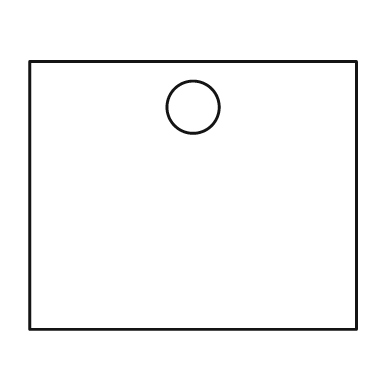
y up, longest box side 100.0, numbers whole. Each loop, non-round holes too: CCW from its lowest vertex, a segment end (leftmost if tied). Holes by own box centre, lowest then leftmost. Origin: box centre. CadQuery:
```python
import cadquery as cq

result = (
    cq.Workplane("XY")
    .moveTo(-50.0, -41.0)
    .lineTo(50.0, -41.0)
    .lineTo(50.0, 41.0)
    .lineTo(-50.0, 41.0)
    .close()
    .moveTo(0.0, 27.0)
    .circle(8.0)
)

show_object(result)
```